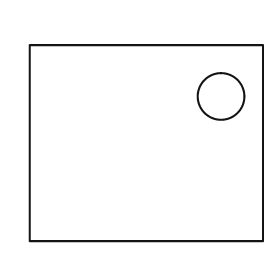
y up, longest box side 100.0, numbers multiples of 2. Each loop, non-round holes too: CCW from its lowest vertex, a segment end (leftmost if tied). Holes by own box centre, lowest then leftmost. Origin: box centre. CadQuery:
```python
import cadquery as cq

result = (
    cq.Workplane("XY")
    .moveTo(-50.0, -42.0)
    .lineTo(50.0, -42.0)
    .lineTo(50.0, 42.0)
    .lineTo(-50.0, 42.0)
    .close()
    .moveTo(32.0, 20.0)
    .circle(10.0)
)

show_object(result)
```